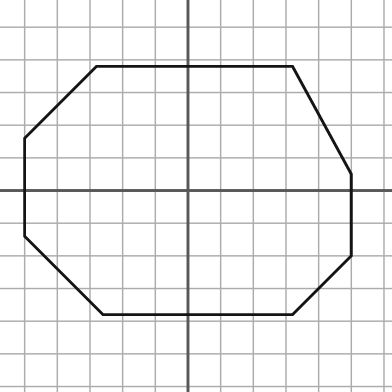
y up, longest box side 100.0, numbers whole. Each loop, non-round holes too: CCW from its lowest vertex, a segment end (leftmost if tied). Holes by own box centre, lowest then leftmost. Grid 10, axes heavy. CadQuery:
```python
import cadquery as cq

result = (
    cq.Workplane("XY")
    .moveTo(-26.0, -38.0)
    .lineTo(32.0, -38.0)
    .lineTo(50.0, -20.0)
    .lineTo(50.0, 5.0)
    .lineTo(32.0, 38.0)
    .lineTo(-28.0, 38.0)
    .lineTo(-50.0, 16.0)
    .lineTo(-50.0, -14.0)
    .close()
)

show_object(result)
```